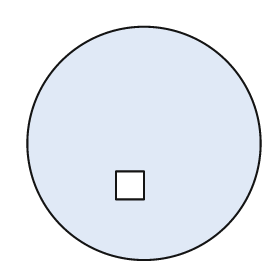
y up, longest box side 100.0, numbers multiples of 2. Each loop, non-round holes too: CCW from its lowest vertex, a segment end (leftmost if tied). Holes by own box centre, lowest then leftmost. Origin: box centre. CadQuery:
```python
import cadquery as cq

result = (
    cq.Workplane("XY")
    .moveTo(0.0, 0.0)
    .circle(50.0)
    .moveTo(-12.0, -24.0)
    .lineTo(0.0, -24.0)
    .lineTo(0.0, -12.0)
    .lineTo(-12.0, -12.0)
    .close()
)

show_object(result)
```